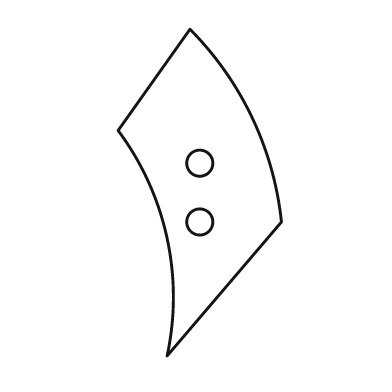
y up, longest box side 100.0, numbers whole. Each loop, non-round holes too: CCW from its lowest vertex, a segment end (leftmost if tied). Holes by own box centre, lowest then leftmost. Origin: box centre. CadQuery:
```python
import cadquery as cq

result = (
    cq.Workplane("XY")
    .moveTo(-10.0, -50.0)
    .lineTo(25.0, -9.0)
    .threePointArc((16.0, 23.0), (-3.0, 50.0))
    .lineTo(-25.0, 19.0)
    .threePointArc((-10.0, -14.0), (-10.0, -50.0))
    .close()
    .moveTo(0.0, -9.0)
    .circle(4.0)
    .moveTo(0.0, 9.0)
    .circle(4.0)
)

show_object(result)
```